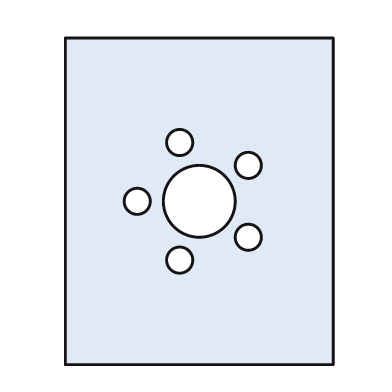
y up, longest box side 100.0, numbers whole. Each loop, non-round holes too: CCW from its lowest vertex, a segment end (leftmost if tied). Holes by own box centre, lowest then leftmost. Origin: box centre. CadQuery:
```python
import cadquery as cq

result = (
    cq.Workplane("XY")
    .moveTo(-41.0, -50.0)
    .lineTo(41.0, -50.0)
    .lineTo(41.0, 50.0)
    .lineTo(-41.0, 50.0)
    .close()
    .moveTo(-6.0, -18.0)
    .circle(4.0)
    .moveTo(15.0, -11.0)
    .circle(4.0)
    .moveTo(-19.0, 0.0)
    .circle(4.0)
    .moveTo(0.0, 0.0)
    .circle(11.0)
    .moveTo(15.0, 11.0)
    .circle(4.0)
    .moveTo(-6.0, 18.0)
    .circle(4.0)
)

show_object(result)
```